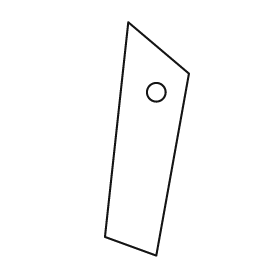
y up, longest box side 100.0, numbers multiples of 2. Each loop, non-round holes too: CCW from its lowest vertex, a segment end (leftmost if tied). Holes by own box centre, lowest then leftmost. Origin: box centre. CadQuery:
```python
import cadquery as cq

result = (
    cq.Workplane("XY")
    .moveTo(4.0, -50.0)
    .lineTo(18.0, 28.0)
    .lineTo(-8.0, 50.0)
    .lineTo(-18.0, -42.0)
    .close()
    .moveTo(4.0, 20.0)
    .circle(4.0)
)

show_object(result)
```